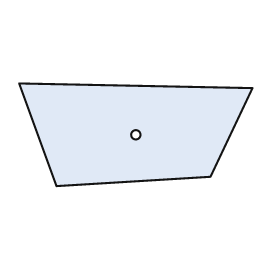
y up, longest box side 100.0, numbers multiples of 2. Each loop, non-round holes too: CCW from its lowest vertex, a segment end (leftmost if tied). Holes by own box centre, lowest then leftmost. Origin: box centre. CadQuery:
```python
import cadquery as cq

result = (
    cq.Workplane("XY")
    .moveTo(-34.0, -22.0)
    .lineTo(32.0, -18.0)
    .lineTo(50.0, 20.0)
    .lineTo(-50.0, 22.0)
    .close()
    .moveTo(0.0, 0.0)
    .circle(2.0)
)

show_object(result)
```